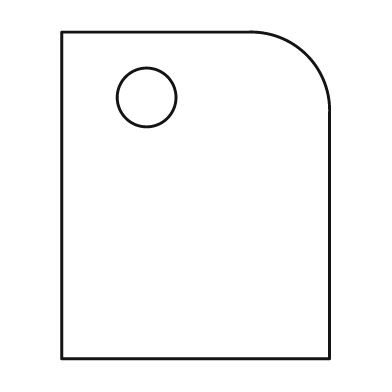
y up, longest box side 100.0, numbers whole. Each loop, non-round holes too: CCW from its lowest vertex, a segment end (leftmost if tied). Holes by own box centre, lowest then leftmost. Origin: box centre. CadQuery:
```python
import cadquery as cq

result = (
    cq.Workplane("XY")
    .moveTo(-41.0, -50.0)
    .lineTo(41.0, -50.0)
    .lineTo(41.0, 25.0)
    .threePointArc((34.0, 43.0), (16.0, 50.0))
    .lineTo(-41.0, 50.0)
    .close()
    .moveTo(-15.0, 30.0)
    .circle(9.0)
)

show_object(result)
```